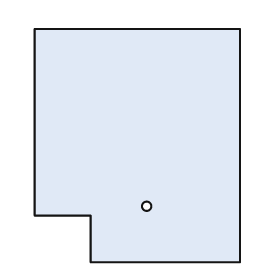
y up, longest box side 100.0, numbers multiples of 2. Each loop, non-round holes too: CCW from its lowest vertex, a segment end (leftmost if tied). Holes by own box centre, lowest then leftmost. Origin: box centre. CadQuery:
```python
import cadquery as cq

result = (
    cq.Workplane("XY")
    .moveTo(-20.0, -50.0)
    .lineTo(44.0, -50.0)
    .lineTo(44.0, 50.0)
    .lineTo(-44.0, 50.0)
    .lineTo(-44.0, -30.0)
    .lineTo(-20.0, -30.0)
    .close()
    .moveTo(4.0, -26.0)
    .circle(2.0)
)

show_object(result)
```